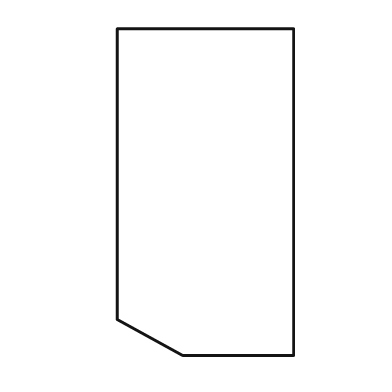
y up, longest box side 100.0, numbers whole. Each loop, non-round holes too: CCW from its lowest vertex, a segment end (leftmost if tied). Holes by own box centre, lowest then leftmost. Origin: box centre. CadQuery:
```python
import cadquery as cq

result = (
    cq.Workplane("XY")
    .moveTo(-7.0, -50.0)
    .lineTo(27.0, -50.0)
    .lineTo(27.0, 50.0)
    .lineTo(-27.0, 50.0)
    .lineTo(-27.0, -39.0)
    .close()
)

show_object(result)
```